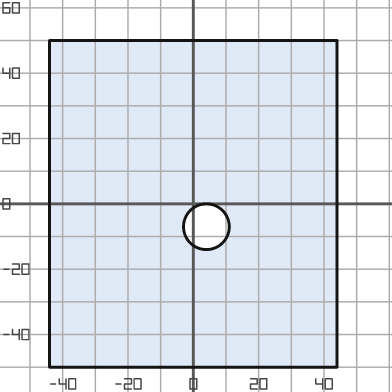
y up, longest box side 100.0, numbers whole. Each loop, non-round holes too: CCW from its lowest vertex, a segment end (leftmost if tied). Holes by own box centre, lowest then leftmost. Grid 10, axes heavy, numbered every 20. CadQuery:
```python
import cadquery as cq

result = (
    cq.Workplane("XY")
    .moveTo(-44.0, -50.0)
    .lineTo(44.0, -50.0)
    .lineTo(44.0, 50.0)
    .lineTo(-44.0, 50.0)
    .close()
    .moveTo(4.0, -7.0)
    .circle(7.0)
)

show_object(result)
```